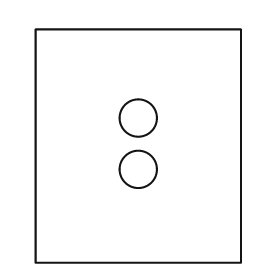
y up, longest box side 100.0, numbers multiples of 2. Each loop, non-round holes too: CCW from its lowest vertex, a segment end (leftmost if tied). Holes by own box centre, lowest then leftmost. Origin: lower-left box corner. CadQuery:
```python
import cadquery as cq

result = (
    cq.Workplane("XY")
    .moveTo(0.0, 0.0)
    .lineTo(88.0, 0.0)
    .lineTo(88.0, 100.0)
    .lineTo(0.0, 100.0)
    .close()
    .moveTo(44.0, 40.0)
    .circle(8.0)
    .moveTo(44.0, 62.0)
    .circle(8.0)
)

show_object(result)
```